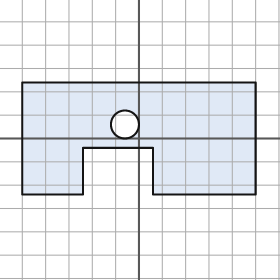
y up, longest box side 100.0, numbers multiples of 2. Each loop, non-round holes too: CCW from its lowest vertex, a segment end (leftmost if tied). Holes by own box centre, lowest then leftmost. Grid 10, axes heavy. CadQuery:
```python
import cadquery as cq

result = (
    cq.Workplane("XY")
    .moveTo(-50.0, -24.0)
    .lineTo(-24.0, -24.0)
    .lineTo(-24.0, -4.0)
    .lineTo(6.0, -4.0)
    .lineTo(6.0, -24.0)
    .lineTo(50.0, -24.0)
    .lineTo(50.0, 24.0)
    .lineTo(-50.0, 24.0)
    .close()
    .moveTo(-6.0, 6.0)
    .circle(6.0)
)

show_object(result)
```